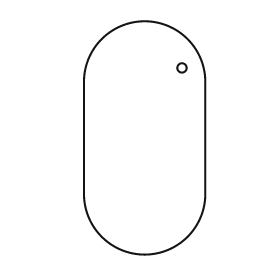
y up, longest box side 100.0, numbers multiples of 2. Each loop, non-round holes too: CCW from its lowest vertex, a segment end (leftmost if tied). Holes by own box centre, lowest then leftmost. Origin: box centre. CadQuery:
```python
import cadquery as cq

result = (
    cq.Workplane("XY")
    .moveTo(-26.0, -24.0)
    .threePointArc((0.0, -50.0), (26.0, -24.0))
    .lineTo(26.0, 24.0)
    .threePointArc((0.0, 50.0), (-26.0, 24.0))
    .close()
    .moveTo(16.0, 30.0)
    .circle(2.0)
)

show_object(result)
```